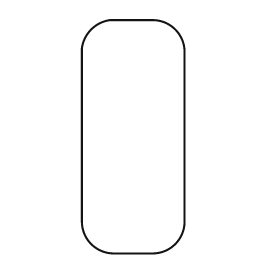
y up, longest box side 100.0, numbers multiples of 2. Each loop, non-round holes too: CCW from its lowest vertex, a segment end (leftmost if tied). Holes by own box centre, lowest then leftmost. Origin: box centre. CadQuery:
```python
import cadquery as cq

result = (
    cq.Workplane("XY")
    .moveTo(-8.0, -50.0)
    .lineTo(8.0, -50.0)
    .threePointArc((18.0, -46.0), (22.0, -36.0))
    .lineTo(22.0, 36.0)
    .threePointArc((18.0, 46.0), (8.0, 50.0))
    .lineTo(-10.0, 50.0)
    .threePointArc((-18.0, 46.0), (-22.0, 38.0))
    .lineTo(-22.0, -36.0)
    .threePointArc((-18.0, -46.0), (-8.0, -50.0))
    .close()
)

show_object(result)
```